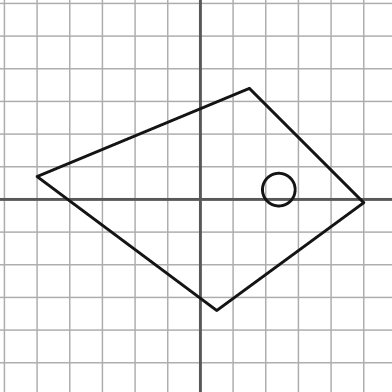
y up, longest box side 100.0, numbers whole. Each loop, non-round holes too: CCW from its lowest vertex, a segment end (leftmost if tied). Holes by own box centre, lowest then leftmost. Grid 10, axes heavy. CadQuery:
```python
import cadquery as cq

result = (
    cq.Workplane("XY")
    .moveTo(5.0, -34.0)
    .lineTo(50.0, -1.0)
    .lineTo(15.0, 34.0)
    .lineTo(-50.0, 7.0)
    .close()
    .moveTo(24.0, 3.0)
    .circle(5.0)
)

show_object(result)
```